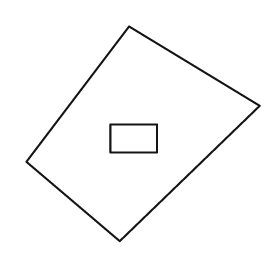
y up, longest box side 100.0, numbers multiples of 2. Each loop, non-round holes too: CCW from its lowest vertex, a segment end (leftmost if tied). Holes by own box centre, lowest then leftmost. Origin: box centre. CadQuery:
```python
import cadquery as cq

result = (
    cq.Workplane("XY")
    .moveTo(-10.0, -46.0)
    .lineTo(50.0, 12.0)
    .lineTo(-6.0, 46.0)
    .lineTo(-50.0, -12.0)
    .close()
    .moveTo(-14.0, -8.0)
    .lineTo(6.0, -8.0)
    .lineTo(6.0, 4.0)
    .lineTo(-14.0, 4.0)
    .close()
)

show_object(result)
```